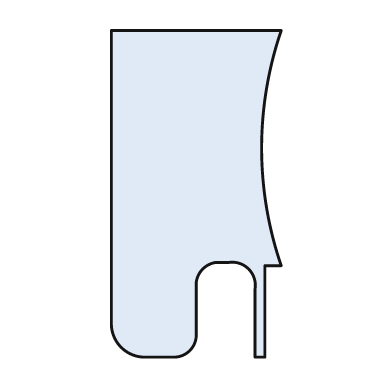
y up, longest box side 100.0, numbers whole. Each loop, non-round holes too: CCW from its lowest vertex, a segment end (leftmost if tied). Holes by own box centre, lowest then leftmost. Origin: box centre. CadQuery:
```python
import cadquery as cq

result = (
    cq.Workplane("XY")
    .moveTo(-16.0, -50.0)
    .lineTo(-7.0, -50.0)
    .threePointArc((-2.0, -48.0), (0.0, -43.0))
    .lineTo(0.0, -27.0)
    .threePointArc((2.0, -23.0), (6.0, -21.0))
    .lineTo(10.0, -21.0)
    .threePointArc((16.0, -23.0), (18.0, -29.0))
    .lineTo(18.0, -50.0)
    .lineTo(21.0, -50.0)
    .lineTo(21.0, -22.0)
    .lineTo(26.0, -22.0)
    .threePointArc((20.0, 14.0), (26.0, 50.0))
    .lineTo(-26.0, 50.0)
    .lineTo(-26.0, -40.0)
    .threePointArc((-23.0, -47.0), (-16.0, -50.0))
    .close()
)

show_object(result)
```